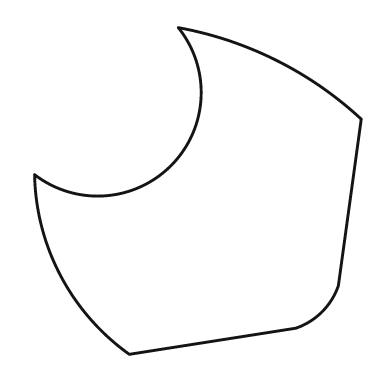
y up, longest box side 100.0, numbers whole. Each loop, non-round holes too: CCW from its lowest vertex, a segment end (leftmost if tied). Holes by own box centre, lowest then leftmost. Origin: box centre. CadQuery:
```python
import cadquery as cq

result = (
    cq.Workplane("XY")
    .moveTo(-21.0, -50.0)
    .lineTo(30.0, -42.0)
    .threePointArc((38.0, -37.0), (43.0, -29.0))
    .lineTo(50.0, 22.0)
    .threePointArc((24.0, 40.0), (-6.0, 50.0))
    .threePointArc((-8.0, 8.0), (-50.0, 5.0))
    .threePointArc((-42.0, -26.0), (-21.0, -50.0))
    .close()
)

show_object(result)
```